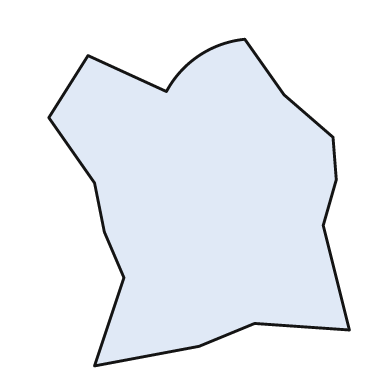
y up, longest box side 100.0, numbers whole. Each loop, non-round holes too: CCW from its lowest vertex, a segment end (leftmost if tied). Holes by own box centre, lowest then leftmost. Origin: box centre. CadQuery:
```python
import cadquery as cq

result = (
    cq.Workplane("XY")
    .moveTo(-32.0, -50.0)
    .lineTo(0.0, -44.0)
    .lineTo(17.0, -37.0)
    .lineTo(46.0, -39.0)
    .lineTo(38.0, -7.0)
    .lineTo(42.0, 7.0)
    .lineTo(41.0, 20.0)
    .lineTo(26.0, 33.0)
    .lineTo(14.0, 50.0)
    .threePointArc((0.0, 45.0), (-10.0, 34.0))
    .lineTo(-34.0, 45.0)
    .lineTo(-46.0, 26.0)
    .lineTo(-32.0, 6.0)
    .lineTo(-29.0, -9.0)
    .lineTo(-23.0, -23.0)
    .close()
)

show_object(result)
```